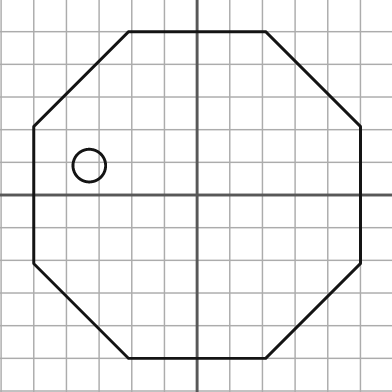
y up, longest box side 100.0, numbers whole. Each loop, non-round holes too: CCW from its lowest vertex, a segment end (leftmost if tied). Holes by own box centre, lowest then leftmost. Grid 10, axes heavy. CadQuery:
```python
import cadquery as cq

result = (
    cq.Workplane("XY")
    .moveTo(-21.0, -50.0)
    .lineTo(21.0, -50.0)
    .lineTo(50.0, -21.0)
    .lineTo(50.0, 21.0)
    .lineTo(21.0, 50.0)
    .lineTo(-21.0, 50.0)
    .lineTo(-50.0, 21.0)
    .lineTo(-50.0, -21.0)
    .close()
    .moveTo(-33.0, 9.0)
    .circle(5.0)
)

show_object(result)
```